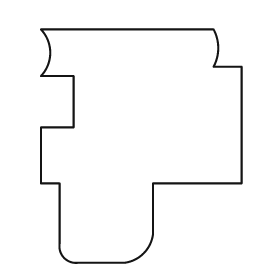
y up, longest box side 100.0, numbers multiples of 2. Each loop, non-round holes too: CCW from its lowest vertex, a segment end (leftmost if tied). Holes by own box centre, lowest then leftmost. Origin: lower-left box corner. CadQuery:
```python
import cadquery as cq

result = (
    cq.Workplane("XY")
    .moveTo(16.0, 0.0)
    .lineTo(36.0, 0.0)
    .threePointArc((44.0, 4.0), (48.0, 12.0))
    .lineTo(48.0, 34.0)
    .lineTo(86.0, 34.0)
    .lineTo(86.0, 84.0)
    .lineTo(74.0, 84.0)
    .threePointArc((76.0, 92.0), (74.0, 100.0))
    .lineTo(0.0, 100.0)
    .threePointArc((4.0, 90.0), (0.0, 80.0))
    .lineTo(14.0, 80.0)
    .lineTo(14.0, 58.0)
    .lineTo(0.0, 58.0)
    .lineTo(0.0, 34.0)
    .lineTo(8.0, 34.0)
    .lineTo(8.0, 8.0)
    .threePointArc((10.0, 2.0), (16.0, 0.0))
    .close()
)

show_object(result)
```